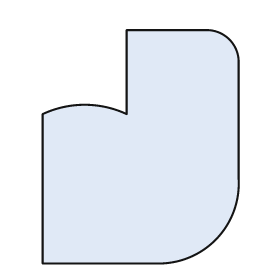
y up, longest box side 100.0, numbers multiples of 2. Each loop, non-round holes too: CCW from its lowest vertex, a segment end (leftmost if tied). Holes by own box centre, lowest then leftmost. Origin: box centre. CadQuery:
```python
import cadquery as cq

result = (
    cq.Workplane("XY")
    .moveTo(-42.0, -50.0)
    .lineTo(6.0, -50.0)
    .threePointArc((32.0, -40.0), (42.0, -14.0))
    .lineTo(42.0, 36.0)
    .threePointArc((38.0, 46.0), (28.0, 50.0))
    .lineTo(-6.0, 50.0)
    .lineTo(-6.0, 14.0)
    .threePointArc((-24.0, 18.0), (-42.0, 14.0))
    .close()
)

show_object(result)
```